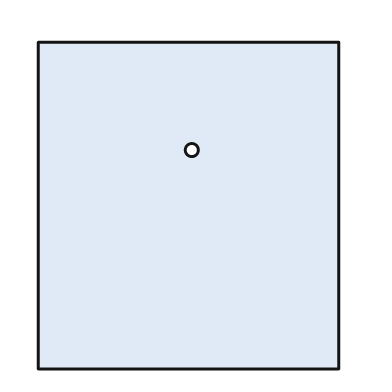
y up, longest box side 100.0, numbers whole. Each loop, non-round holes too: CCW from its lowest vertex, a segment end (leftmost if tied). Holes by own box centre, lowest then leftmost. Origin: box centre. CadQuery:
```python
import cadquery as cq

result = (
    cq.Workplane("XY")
    .moveTo(-46.0, -50.0)
    .lineTo(46.0, -50.0)
    .lineTo(46.0, 50.0)
    .lineTo(-46.0, 50.0)
    .close()
    .moveTo(1.0, 17.0)
    .circle(2.0)
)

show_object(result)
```